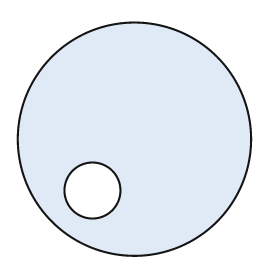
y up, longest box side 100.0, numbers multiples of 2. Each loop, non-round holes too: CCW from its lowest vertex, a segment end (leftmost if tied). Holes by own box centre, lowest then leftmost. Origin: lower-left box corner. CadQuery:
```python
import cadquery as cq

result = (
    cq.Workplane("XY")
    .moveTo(50.0, 50.0)
    .circle(50.0)
    .moveTo(32.0, 28.0)
    .circle(12.0)
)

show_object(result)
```